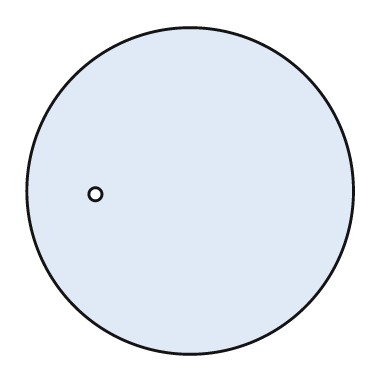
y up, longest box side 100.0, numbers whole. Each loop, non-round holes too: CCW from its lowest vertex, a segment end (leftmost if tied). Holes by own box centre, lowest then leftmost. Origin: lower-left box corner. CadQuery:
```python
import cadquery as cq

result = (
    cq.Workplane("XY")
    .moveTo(50.0, 50.0)
    .circle(50.0)
    .moveTo(21.0, 49.0)
    .circle(2.0)
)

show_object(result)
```